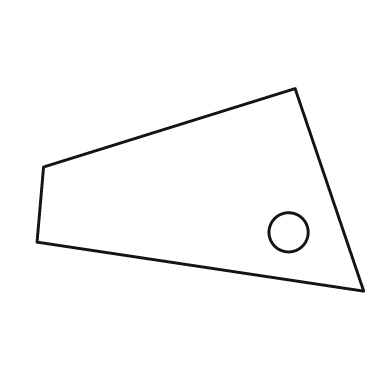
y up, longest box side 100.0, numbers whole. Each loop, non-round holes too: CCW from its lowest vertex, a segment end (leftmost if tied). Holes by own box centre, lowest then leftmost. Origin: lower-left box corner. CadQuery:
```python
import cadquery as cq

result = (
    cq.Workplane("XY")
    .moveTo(100.0, 0.0)
    .lineTo(79.0, 62.0)
    .lineTo(2.0, 38.0)
    .lineTo(0.0, 15.0)
    .close()
    .moveTo(77.0, 18.0)
    .circle(6.0)
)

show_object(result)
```